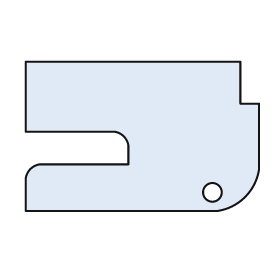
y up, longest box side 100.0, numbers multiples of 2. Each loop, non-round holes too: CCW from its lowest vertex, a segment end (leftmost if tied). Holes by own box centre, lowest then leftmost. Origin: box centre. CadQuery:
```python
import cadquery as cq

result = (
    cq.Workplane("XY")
    .moveTo(-50.0, -32.0)
    .lineTo(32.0, -32.0)
    .threePointArc((44.0, -26.0), (50.0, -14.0))
    .lineTo(50.0, 14.0)
    .lineTo(42.0, 14.0)
    .lineTo(42.0, 32.0)
    .lineTo(-50.0, 32.0)
    .lineTo(-50.0, 2.0)
    .lineTo(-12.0, 2.0)
    .threePointArc((-8.0, 0.0), (-6.0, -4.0))
    .lineTo(-6.0, -12.0)
    .lineTo(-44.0, -12.0)
    .threePointArc((-48.0, -14.0), (-50.0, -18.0))
    .close()
    .moveTo(30.0, -24.0)
    .circle(4.0)
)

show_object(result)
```